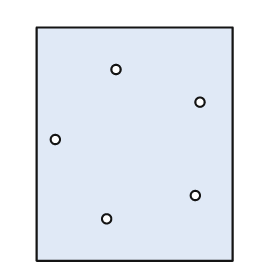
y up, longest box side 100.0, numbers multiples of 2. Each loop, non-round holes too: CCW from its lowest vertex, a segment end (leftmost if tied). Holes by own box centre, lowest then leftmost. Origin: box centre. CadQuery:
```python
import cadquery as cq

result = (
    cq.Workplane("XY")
    .moveTo(-42.0, -50.0)
    .lineTo(42.0, -50.0)
    .lineTo(42.0, 50.0)
    .lineTo(-42.0, 50.0)
    .close()
    .moveTo(-12.0, -32.0)
    .circle(2.0)
    .moveTo(26.0, -22.0)
    .circle(2.0)
    .moveTo(-34.0, 2.0)
    .circle(2.0)
    .moveTo(28.0, 18.0)
    .circle(2.0)
    .moveTo(-8.0, 32.0)
    .circle(2.0)
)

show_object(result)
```